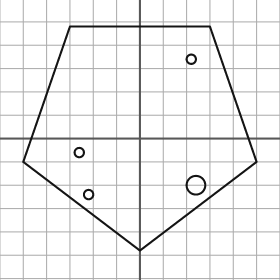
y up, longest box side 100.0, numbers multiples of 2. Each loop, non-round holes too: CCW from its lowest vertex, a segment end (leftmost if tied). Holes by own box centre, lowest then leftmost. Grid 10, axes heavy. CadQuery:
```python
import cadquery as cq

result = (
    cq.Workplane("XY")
    .moveTo(0.0, -48.0)
    .lineTo(50.0, -10.0)
    .lineTo(30.0, 48.0)
    .lineTo(-30.0, 48.0)
    .lineTo(-50.0, -10.0)
    .close()
    .moveTo(-22.0, -24.0)
    .circle(2.0)
    .moveTo(24.0, -20.0)
    .circle(4.0)
    .moveTo(-26.0, -6.0)
    .circle(2.0)
    .moveTo(22.0, 34.0)
    .circle(2.0)
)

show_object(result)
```